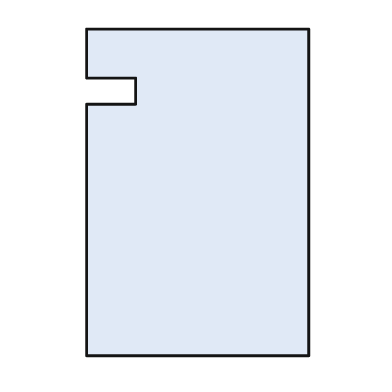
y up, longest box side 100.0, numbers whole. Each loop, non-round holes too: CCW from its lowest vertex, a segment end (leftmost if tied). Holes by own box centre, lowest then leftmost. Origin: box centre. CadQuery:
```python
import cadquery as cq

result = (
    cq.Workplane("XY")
    .moveTo(-34.0, -50.0)
    .lineTo(34.0, -50.0)
    .lineTo(34.0, 50.0)
    .lineTo(-34.0, 50.0)
    .lineTo(-34.0, 35.0)
    .lineTo(-19.0, 35.0)
    .lineTo(-19.0, 27.0)
    .lineTo(-34.0, 27.0)
    .close()
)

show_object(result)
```